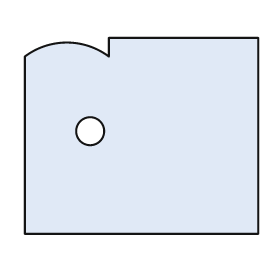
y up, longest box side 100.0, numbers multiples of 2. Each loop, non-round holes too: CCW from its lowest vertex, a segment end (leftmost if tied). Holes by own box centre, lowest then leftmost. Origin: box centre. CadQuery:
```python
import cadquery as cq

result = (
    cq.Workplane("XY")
    .moveTo(-50.0, -42.0)
    .lineTo(50.0, -42.0)
    .lineTo(50.0, 42.0)
    .lineTo(-14.0, 42.0)
    .lineTo(-14.0, 34.0)
    .threePointArc((-32.0, 40.0), (-50.0, 34.0))
    .close()
    .moveTo(-22.0, 2.0)
    .circle(6.0)
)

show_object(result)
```